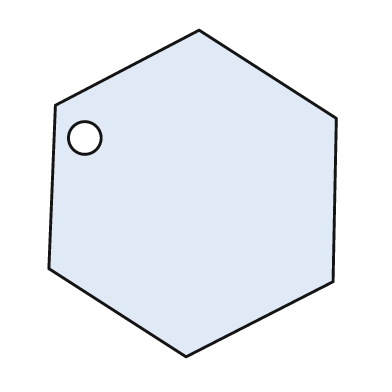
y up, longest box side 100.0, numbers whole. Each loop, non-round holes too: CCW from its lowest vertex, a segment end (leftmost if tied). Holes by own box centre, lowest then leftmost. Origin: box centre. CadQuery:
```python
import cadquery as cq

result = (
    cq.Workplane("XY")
    .moveTo(-2.0, -50.0)
    .lineTo(43.0, -27.0)
    .lineTo(44.0, 23.0)
    .lineTo(2.0, 50.0)
    .lineTo(-42.0, 27.0)
    .lineTo(-44.0, -23.0)
    .close()
    .moveTo(-33.0, 17.0)
    .circle(5.0)
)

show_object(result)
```